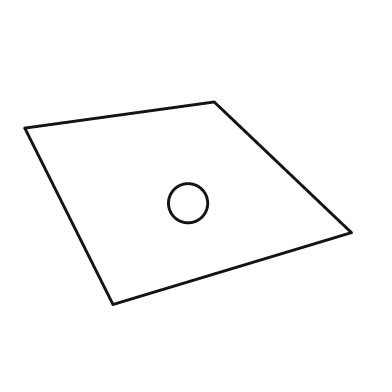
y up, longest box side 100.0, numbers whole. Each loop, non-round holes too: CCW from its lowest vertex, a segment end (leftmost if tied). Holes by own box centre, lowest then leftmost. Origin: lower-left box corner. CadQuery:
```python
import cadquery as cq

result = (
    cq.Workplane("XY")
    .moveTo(27.0, 0.0)
    .lineTo(100.0, 22.0)
    .lineTo(58.0, 62.0)
    .lineTo(0.0, 54.0)
    .close()
    .moveTo(50.0, 31.0)
    .circle(6.0)
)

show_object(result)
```